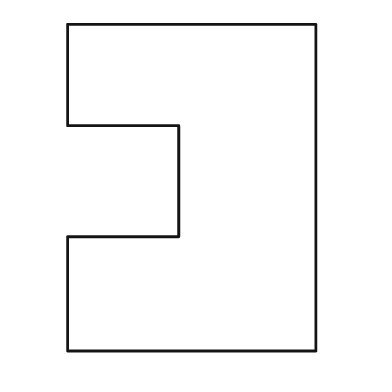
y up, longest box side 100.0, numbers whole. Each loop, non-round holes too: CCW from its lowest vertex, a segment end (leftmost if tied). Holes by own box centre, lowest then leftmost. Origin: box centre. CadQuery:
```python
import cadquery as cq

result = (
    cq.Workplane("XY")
    .moveTo(-38.0, -50.0)
    .lineTo(38.0, -50.0)
    .lineTo(38.0, 50.0)
    .lineTo(-38.0, 50.0)
    .lineTo(-38.0, 19.0)
    .lineTo(-4.0, 19.0)
    .lineTo(-4.0, -15.0)
    .lineTo(-38.0, -15.0)
    .close()
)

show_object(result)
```